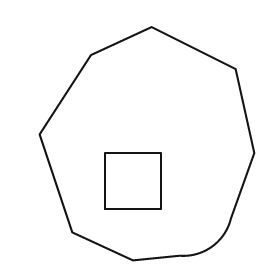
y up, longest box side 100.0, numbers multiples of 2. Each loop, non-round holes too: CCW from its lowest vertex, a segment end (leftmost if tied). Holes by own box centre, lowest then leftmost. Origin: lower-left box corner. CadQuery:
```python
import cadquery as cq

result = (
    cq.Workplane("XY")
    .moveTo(40.0, 0.0)
    .lineTo(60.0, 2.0)
    .threePointArc((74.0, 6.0), (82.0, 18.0))
    .lineTo(92.0, 46.0)
    .lineTo(84.0, 82.0)
    .lineTo(48.0, 100.0)
    .lineTo(22.0, 88.0)
    .lineTo(0.0, 54.0)
    .lineTo(14.0, 12.0)
    .close()
    .moveTo(28.0, 22.0)
    .lineTo(52.0, 22.0)
    .lineTo(52.0, 46.0)
    .lineTo(28.0, 46.0)
    .close()
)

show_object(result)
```